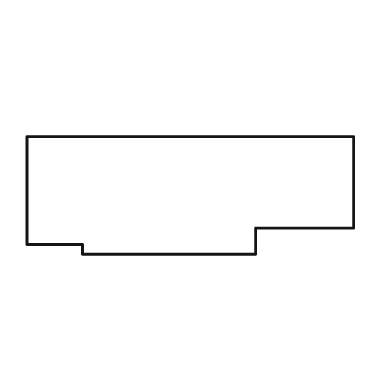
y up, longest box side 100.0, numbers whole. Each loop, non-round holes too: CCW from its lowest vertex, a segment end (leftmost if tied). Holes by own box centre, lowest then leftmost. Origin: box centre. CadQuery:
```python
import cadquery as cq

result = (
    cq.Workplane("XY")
    .moveTo(-33.0, -18.0)
    .lineTo(20.0, -18.0)
    .lineTo(20.0, -10.0)
    .lineTo(50.0, -10.0)
    .lineTo(50.0, 18.0)
    .lineTo(-50.0, 18.0)
    .lineTo(-50.0, -15.0)
    .lineTo(-33.0, -15.0)
    .close()
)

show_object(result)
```